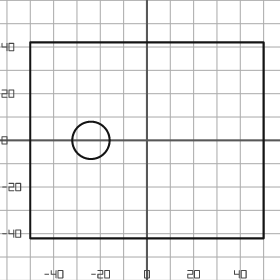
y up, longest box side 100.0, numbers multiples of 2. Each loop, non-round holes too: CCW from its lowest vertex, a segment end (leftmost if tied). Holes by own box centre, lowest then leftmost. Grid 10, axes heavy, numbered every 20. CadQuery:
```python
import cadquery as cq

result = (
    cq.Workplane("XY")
    .moveTo(-50.0, -42.0)
    .lineTo(50.0, -42.0)
    .lineTo(50.0, 42.0)
    .lineTo(-50.0, 42.0)
    .close()
    .moveTo(-24.0, 0.0)
    .circle(8.0)
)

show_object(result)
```